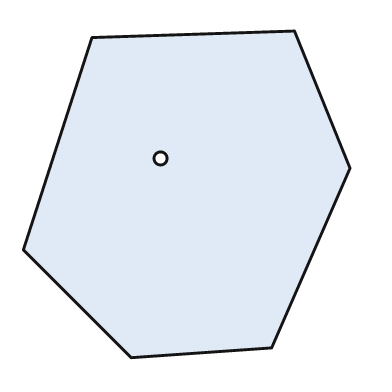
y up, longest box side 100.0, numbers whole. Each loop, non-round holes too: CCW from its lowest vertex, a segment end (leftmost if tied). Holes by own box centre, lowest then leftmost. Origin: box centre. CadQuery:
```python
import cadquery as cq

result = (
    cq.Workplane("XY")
    .moveTo(-17.0, -50.0)
    .lineTo(26.0, -47.0)
    .lineTo(50.0, 8.0)
    .lineTo(33.0, 50.0)
    .lineTo(-29.0, 48.0)
    .lineTo(-50.0, -17.0)
    .close()
    .moveTo(-8.0, 11.0)
    .circle(2.0)
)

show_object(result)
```